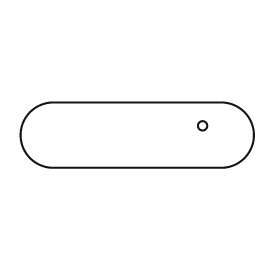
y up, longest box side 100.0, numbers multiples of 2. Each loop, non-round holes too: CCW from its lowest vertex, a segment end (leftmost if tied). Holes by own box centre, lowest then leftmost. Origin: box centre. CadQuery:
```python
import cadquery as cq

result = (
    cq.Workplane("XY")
    .moveTo(-36.0, -14.0)
    .lineTo(36.0, -14.0)
    .threePointArc((50.0, 0.0), (36.0, 14.0))
    .lineTo(-36.0, 14.0)
    .threePointArc((-50.0, 0.0), (-36.0, -14.0))
    .close()
    .moveTo(28.0, 4.0)
    .circle(2.0)
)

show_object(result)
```